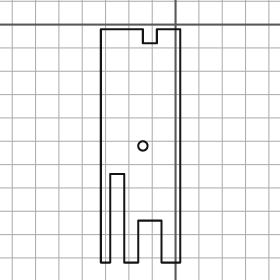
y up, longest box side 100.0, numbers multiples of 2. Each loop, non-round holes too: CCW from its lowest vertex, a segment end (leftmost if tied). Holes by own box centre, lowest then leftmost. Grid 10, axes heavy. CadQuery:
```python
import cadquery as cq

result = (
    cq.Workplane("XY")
    .moveTo(-32.0, -102.0)
    .lineTo(-28.0, -102.0)
    .lineTo(-28.0, -64.0)
    .lineTo(-22.0, -64.0)
    .lineTo(-22.0, -102.0)
    .lineTo(-16.0, -102.0)
    .lineTo(-16.0, -84.0)
    .lineTo(-6.0, -84.0)
    .lineTo(-6.0, -102.0)
    .lineTo(2.0, -102.0)
    .lineTo(2.0, -2.0)
    .lineTo(-8.0, -2.0)
    .lineTo(-8.0, -8.0)
    .lineTo(-14.0, -8.0)
    .lineTo(-14.0, -2.0)
    .lineTo(-32.0, -2.0)
    .close()
    .moveTo(-14.0, -52.0)
    .circle(2.0)
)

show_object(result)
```